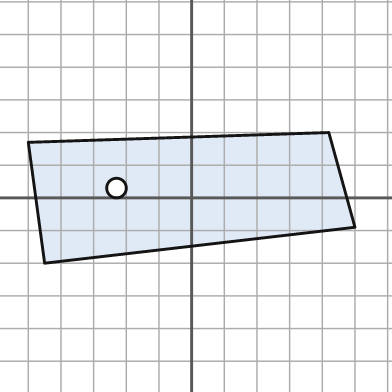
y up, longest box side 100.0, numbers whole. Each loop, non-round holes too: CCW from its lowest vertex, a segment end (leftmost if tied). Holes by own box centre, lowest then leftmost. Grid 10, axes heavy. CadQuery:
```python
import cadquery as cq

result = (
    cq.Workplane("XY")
    .moveTo(-45.0, -20.0)
    .lineTo(50.0, -9.0)
    .lineTo(42.0, 20.0)
    .lineTo(-50.0, 17.0)
    .close()
    .moveTo(-23.0, 3.0)
    .circle(3.0)
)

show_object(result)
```